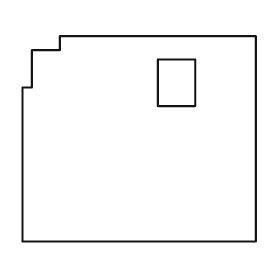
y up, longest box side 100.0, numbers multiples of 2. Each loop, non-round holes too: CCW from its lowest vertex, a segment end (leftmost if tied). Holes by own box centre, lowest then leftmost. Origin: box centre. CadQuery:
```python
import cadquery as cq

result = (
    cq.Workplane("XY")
    .moveTo(-50.0, -44.0)
    .lineTo(50.0, -44.0)
    .lineTo(50.0, 44.0)
    .lineTo(-34.0, 44.0)
    .lineTo(-34.0, 38.0)
    .lineTo(-46.0, 38.0)
    .lineTo(-46.0, 22.0)
    .lineTo(-50.0, 22.0)
    .close()
    .moveTo(8.0, 14.0)
    .lineTo(24.0, 14.0)
    .lineTo(24.0, 34.0)
    .lineTo(8.0, 34.0)
    .close()
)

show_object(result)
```